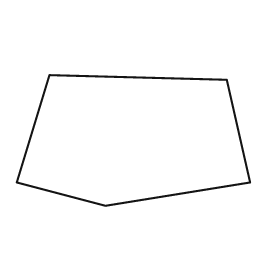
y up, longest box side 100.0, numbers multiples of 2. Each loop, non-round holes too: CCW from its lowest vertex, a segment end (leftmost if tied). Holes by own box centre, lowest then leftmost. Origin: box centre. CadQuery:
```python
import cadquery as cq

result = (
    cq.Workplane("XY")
    .moveTo(-12.0, -28.0)
    .lineTo(50.0, -18.0)
    .lineTo(40.0, 26.0)
    .lineTo(-36.0, 28.0)
    .lineTo(-50.0, -18.0)
    .close()
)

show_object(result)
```